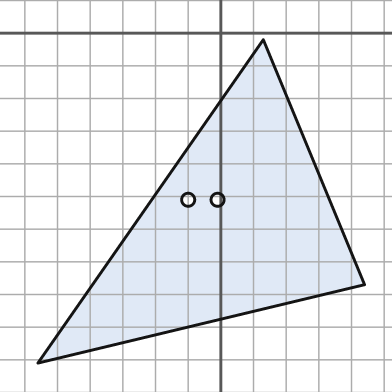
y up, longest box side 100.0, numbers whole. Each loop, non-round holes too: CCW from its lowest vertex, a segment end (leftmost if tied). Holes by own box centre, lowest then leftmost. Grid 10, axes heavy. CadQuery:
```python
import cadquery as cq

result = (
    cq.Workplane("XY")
    .moveTo(-56.0, -101.0)
    .lineTo(44.0, -77.0)
    .lineTo(13.0, -2.0)
    .close()
    .moveTo(-10.0, -51.0)
    .circle(2.0)
    .moveTo(-1.0, -51.0)
    .circle(2.0)
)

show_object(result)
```